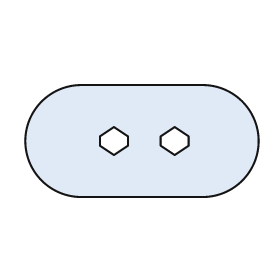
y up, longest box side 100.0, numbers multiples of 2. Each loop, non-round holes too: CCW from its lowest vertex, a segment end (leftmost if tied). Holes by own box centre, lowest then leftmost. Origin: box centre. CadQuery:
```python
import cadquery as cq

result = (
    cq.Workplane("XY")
    .moveTo(-26.0, -24.0)
    .lineTo(26.0, -24.0)
    .threePointArc((50.0, 0.0), (26.0, 24.0))
    .lineTo(-26.0, 24.0)
    .threePointArc((-50.0, 0.0), (-26.0, -24.0))
    .close()
    .moveTo(-12.0, -6.0)
    .lineTo(-6.0, -2.0)
    .lineTo(-6.0, 2.0)
    .lineTo(-12.0, 6.0)
    .lineTo(-18.0, 2.0)
    .lineTo(-18.0, -2.0)
    .close()
    .moveTo(14.0, -6.0)
    .lineTo(20.0, -2.0)
    .lineTo(20.0, 2.0)
    .lineTo(14.0, 6.0)
    .lineTo(8.0, 2.0)
    .lineTo(8.0, -2.0)
    .close()
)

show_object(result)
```